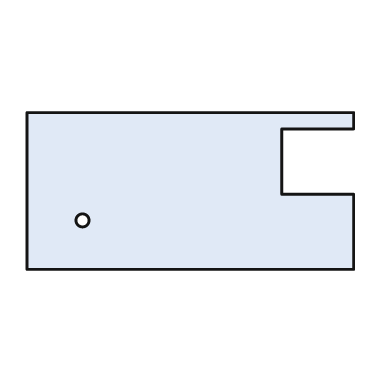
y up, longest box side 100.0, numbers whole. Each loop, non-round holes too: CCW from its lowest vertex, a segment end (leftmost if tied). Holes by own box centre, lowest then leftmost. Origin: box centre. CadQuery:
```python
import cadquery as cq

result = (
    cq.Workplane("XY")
    .moveTo(-50.0, -24.0)
    .lineTo(50.0, -24.0)
    .lineTo(50.0, -1.0)
    .lineTo(28.0, -1.0)
    .lineTo(28.0, 19.0)
    .lineTo(50.0, 19.0)
    .lineTo(50.0, 24.0)
    .lineTo(-50.0, 24.0)
    .close()
    .moveTo(-33.0, -9.0)
    .circle(2.0)
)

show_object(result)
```